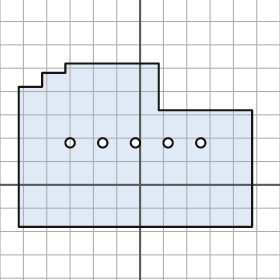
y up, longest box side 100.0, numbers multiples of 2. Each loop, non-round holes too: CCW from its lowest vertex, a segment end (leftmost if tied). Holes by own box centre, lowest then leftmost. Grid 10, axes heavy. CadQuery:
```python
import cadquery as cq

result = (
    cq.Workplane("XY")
    .moveTo(-52.0, -18.0)
    .lineTo(48.0, -18.0)
    .lineTo(48.0, 32.0)
    .lineTo(8.0, 32.0)
    .lineTo(8.0, 52.0)
    .lineTo(-32.0, 52.0)
    .lineTo(-32.0, 48.0)
    .lineTo(-42.0, 48.0)
    .lineTo(-42.0, 42.0)
    .lineTo(-52.0, 42.0)
    .close()
    .moveTo(-30.0, 18.0)
    .circle(2.0)
    .moveTo(-16.0, 18.0)
    .circle(2.0)
    .moveTo(-2.0, 18.0)
    .circle(2.0)
    .moveTo(12.0, 18.0)
    .circle(2.0)
    .moveTo(26.0, 18.0)
    .circle(2.0)
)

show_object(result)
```